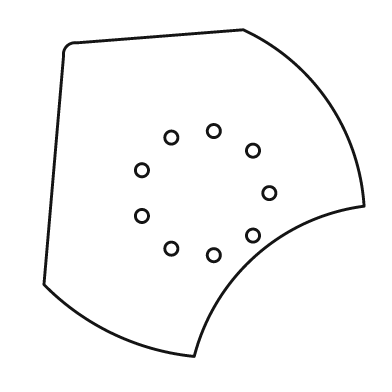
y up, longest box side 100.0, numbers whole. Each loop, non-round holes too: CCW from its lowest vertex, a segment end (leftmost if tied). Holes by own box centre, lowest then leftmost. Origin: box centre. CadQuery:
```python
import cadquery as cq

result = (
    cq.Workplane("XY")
    .moveTo(-3.0, -50.0)
    .threePointArc((16.0, -19.0), (49.0, -4.0))
    .threePointArc((38.0, 28.0), (12.0, 50.0))
    .lineTo(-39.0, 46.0)
    .threePointArc((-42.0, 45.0), (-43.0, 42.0))
    .lineTo(-49.0, -28.0)
    .threePointArc((-28.0, -43.0), (-3.0, -50.0))
    .close()
    .moveTo(3.0, -19.0)
    .circle(2.0)
    .moveTo(-10.0, -17.0)
    .circle(2.0)
    .moveTo(15.0, -13.0)
    .circle(2.0)
    .moveTo(-19.0, -7.0)
    .circle(2.0)
    .moveTo(20.0, 0.0)
    .circle(2.0)
    .moveTo(-19.0, 7.0)
    .circle(2.0)
    .moveTo(15.0, 13.0)
    .circle(2.0)
    .moveTo(-10.0, 17.0)
    .circle(2.0)
    .moveTo(3.0, 19.0)
    .circle(2.0)
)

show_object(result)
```